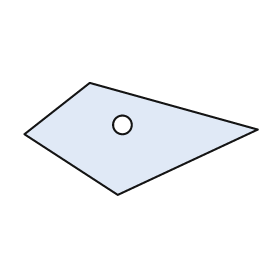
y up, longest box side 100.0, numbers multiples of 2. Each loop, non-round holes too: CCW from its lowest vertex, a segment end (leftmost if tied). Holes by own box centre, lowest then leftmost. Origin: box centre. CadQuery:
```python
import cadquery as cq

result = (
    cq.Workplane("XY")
    .moveTo(-10.0, -24.0)
    .lineTo(50.0, 4.0)
    .lineTo(-22.0, 24.0)
    .lineTo(-50.0, 2.0)
    .close()
    .moveTo(-8.0, 6.0)
    .circle(4.0)
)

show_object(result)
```